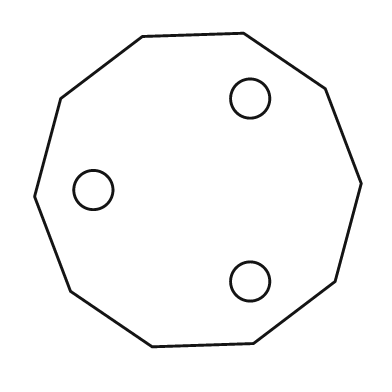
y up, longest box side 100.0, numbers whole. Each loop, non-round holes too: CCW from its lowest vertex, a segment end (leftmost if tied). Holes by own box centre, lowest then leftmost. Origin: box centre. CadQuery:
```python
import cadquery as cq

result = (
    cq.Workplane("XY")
    .moveTo(-14.0, -48.0)
    .lineTo(17.0, -47.0)
    .lineTo(42.0, -28.0)
    .lineTo(50.0, 2.0)
    .lineTo(39.0, 31.0)
    .lineTo(14.0, 48.0)
    .lineTo(-17.0, 47.0)
    .lineTo(-42.0, 28.0)
    .lineTo(-50.0, -2.0)
    .lineTo(-39.0, -31.0)
    .close()
    .moveTo(16.0, -28.0)
    .circle(6.0)
    .moveTo(-32.0, 0.0)
    .circle(6.0)
    .moveTo(16.0, 28.0)
    .circle(6.0)
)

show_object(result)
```